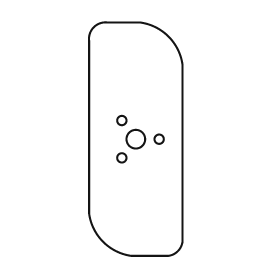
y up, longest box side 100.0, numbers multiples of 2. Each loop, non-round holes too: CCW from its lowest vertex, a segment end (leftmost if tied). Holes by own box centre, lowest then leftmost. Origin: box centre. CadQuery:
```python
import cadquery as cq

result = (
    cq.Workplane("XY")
    .moveTo(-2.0, -50.0)
    .lineTo(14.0, -50.0)
    .threePointArc((18.0, -48.0), (20.0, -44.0))
    .lineTo(20.0, 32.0)
    .threePointArc((14.0, 44.0), (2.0, 50.0))
    .lineTo(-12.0, 50.0)
    .threePointArc((-18.0, 48.0), (-20.0, 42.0))
    .lineTo(-20.0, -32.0)
    .threePointArc((-14.0, -44.0), (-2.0, -50.0))
    .close()
    .moveTo(-6.0, -8.0)
    .circle(2.0)
    .moveTo(0.0, 0.0)
    .circle(4.0)
    .moveTo(10.0, 0.0)
    .circle(2.0)
    .moveTo(-6.0, 8.0)
    .circle(2.0)
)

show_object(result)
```